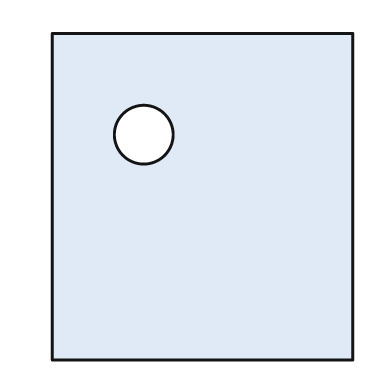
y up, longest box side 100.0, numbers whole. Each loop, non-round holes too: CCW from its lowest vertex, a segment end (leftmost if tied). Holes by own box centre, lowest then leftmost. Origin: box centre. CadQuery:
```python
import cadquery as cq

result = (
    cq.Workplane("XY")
    .moveTo(-46.0, -50.0)
    .lineTo(46.0, -50.0)
    .lineTo(46.0, 50.0)
    .lineTo(-46.0, 50.0)
    .close()
    .moveTo(-18.0, 19.0)
    .circle(9.0)
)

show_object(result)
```